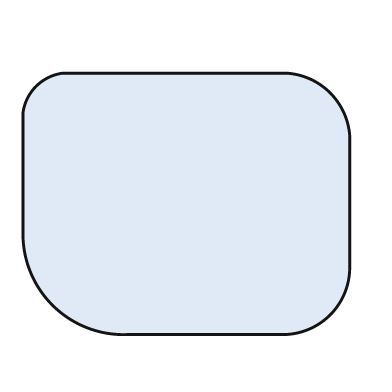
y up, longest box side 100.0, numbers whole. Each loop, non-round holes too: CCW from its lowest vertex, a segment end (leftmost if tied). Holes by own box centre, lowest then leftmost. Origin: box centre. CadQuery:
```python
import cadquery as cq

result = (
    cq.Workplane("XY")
    .moveTo(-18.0, -40.0)
    .lineTo(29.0, -40.0)
    .threePointArc((44.0, -34.0), (50.0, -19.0))
    .lineTo(50.0, 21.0)
    .threePointArc((44.0, 34.0), (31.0, 40.0))
    .lineTo(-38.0, 40.0)
    .threePointArc((-46.0, 36.0), (-50.0, 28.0))
    .lineTo(-50.0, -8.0)
    .threePointArc((-41.0, -31.0), (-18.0, -40.0))
    .close()
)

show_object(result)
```